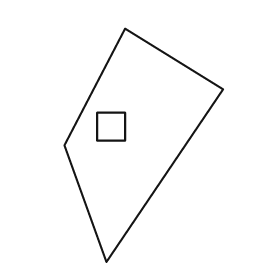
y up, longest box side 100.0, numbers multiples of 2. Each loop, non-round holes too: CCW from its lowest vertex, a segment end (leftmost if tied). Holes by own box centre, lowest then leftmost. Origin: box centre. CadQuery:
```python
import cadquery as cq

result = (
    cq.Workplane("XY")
    .moveTo(-16.0, -50.0)
    .lineTo(34.0, 24.0)
    .lineTo(-8.0, 50.0)
    .lineTo(-34.0, 0.0)
    .close()
    .moveTo(-20.0, 2.0)
    .lineTo(-8.0, 2.0)
    .lineTo(-8.0, 14.0)
    .lineTo(-20.0, 14.0)
    .close()
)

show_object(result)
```